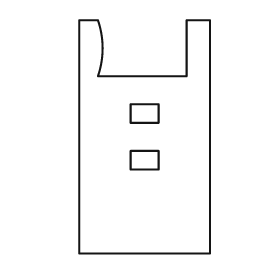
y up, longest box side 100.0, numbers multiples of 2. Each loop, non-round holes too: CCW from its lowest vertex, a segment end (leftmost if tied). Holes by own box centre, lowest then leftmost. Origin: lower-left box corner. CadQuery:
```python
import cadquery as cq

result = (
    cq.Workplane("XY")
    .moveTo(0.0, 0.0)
    .lineTo(56.0, 0.0)
    .lineTo(56.0, 100.0)
    .lineTo(46.0, 100.0)
    .lineTo(46.0, 76.0)
    .lineTo(8.0, 76.0)
    .threePointArc((10.0, 88.0), (8.0, 100.0))
    .lineTo(0.0, 100.0)
    .close()
    .moveTo(22.0, 36.0)
    .lineTo(34.0, 36.0)
    .lineTo(34.0, 44.0)
    .lineTo(22.0, 44.0)
    .close()
    .moveTo(22.0, 56.0)
    .lineTo(34.0, 56.0)
    .lineTo(34.0, 64.0)
    .lineTo(22.0, 64.0)
    .close()
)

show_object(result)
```